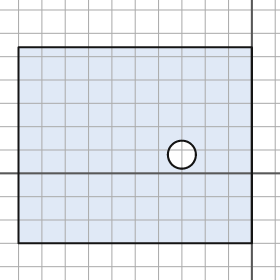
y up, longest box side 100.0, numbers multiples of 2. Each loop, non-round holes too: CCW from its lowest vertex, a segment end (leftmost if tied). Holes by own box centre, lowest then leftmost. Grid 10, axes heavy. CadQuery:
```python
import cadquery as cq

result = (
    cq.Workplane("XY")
    .moveTo(-100.0, -30.0)
    .lineTo(0.0, -30.0)
    .lineTo(0.0, 54.0)
    .lineTo(-100.0, 54.0)
    .close()
    .moveTo(-30.0, 8.0)
    .circle(6.0)
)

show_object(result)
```